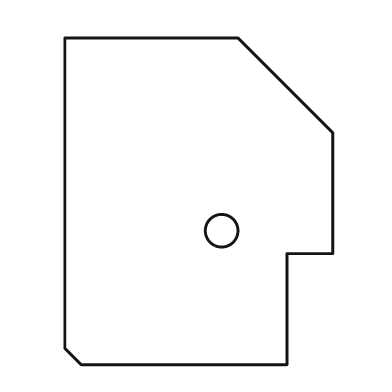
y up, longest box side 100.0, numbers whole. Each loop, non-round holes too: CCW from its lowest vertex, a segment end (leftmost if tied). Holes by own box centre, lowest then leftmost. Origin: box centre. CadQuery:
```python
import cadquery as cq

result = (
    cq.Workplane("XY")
    .moveTo(-36.0, -50.0)
    .lineTo(27.0, -50.0)
    .lineTo(27.0, -16.0)
    .lineTo(41.0, -16.0)
    .lineTo(41.0, 21.0)
    .lineTo(12.0, 50.0)
    .lineTo(-41.0, 50.0)
    .lineTo(-41.0, -45.0)
    .close()
    .moveTo(7.0, -9.0)
    .circle(5.0)
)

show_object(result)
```